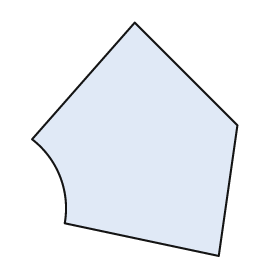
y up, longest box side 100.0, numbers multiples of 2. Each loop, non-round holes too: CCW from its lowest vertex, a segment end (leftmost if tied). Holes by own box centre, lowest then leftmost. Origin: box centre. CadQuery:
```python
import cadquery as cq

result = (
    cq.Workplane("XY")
    .moveTo(36.0, -50.0)
    .lineTo(44.0, 6.0)
    .lineTo(0.0, 50.0)
    .lineTo(-44.0, 0.0)
    .threePointArc((-32.0, -16.0), (-30.0, -36.0))
    .close()
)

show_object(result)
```